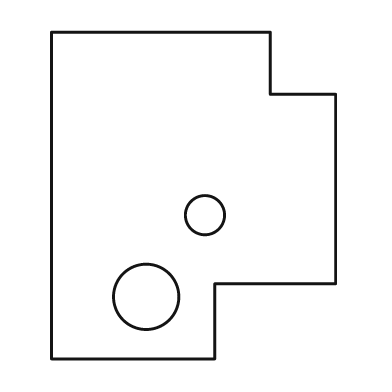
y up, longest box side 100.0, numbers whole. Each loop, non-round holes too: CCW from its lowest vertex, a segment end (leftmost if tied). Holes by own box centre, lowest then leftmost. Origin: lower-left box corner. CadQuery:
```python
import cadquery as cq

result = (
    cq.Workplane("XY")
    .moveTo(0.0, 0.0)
    .lineTo(50.0, 0.0)
    .lineTo(50.0, 23.0)
    .lineTo(87.0, 23.0)
    .lineTo(87.0, 81.0)
    .lineTo(67.0, 81.0)
    .lineTo(67.0, 100.0)
    .lineTo(0.0, 100.0)
    .close()
    .moveTo(29.0, 19.0)
    .circle(10.0)
    .moveTo(47.0, 44.0)
    .circle(6.0)
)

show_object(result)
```